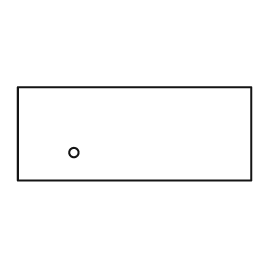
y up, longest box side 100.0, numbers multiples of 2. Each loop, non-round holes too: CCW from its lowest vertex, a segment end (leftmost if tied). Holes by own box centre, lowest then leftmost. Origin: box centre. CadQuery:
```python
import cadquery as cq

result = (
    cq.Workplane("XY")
    .moveTo(-50.0, -20.0)
    .lineTo(50.0, -20.0)
    .lineTo(50.0, 20.0)
    .lineTo(-50.0, 20.0)
    .close()
    .moveTo(-26.0, -8.0)
    .circle(2.0)
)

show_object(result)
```